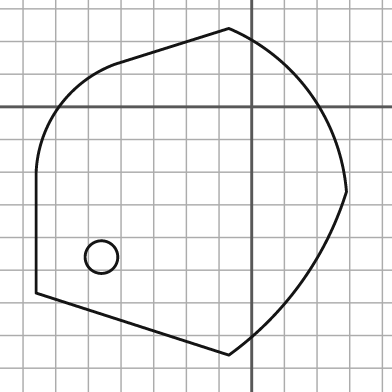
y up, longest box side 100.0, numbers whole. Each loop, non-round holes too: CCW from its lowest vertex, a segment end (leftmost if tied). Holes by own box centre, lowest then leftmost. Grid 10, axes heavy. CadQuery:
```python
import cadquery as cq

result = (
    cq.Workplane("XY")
    .moveTo(-7.0, -76.0)
    .threePointArc((15.0, -54.0), (29.0, -26.0))
    .threePointArc((18.0, 4.0), (-7.0, 24.0))
    .lineTo(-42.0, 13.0)
    .threePointArc((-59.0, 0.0), (-66.0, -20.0))
    .lineTo(-66.0, -57.0)
    .close()
    .moveTo(-46.0, -46.0)
    .circle(5.0)
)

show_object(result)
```